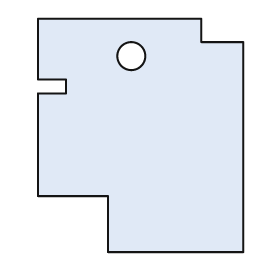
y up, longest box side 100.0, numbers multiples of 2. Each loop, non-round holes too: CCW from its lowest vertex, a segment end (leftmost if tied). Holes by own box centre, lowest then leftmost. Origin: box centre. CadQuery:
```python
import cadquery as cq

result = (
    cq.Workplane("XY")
    .moveTo(-14.0, -50.0)
    .lineTo(44.0, -50.0)
    .lineTo(44.0, 40.0)
    .lineTo(26.0, 40.0)
    .lineTo(26.0, 50.0)
    .lineTo(-44.0, 50.0)
    .lineTo(-44.0, 24.0)
    .lineTo(-32.0, 24.0)
    .lineTo(-32.0, 18.0)
    .lineTo(-44.0, 18.0)
    .lineTo(-44.0, -26.0)
    .lineTo(-14.0, -26.0)
    .close()
    .moveTo(-4.0, 34.0)
    .circle(6.0)
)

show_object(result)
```